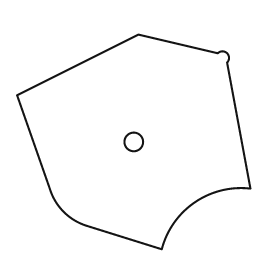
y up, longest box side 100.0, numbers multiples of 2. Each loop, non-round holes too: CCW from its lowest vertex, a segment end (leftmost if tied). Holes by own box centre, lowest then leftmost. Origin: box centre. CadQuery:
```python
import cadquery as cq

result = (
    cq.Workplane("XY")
    .moveTo(12.0, -46.0)
    .threePointArc((26.0, -26.0), (50.0, -20.0))
    .lineTo(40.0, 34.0)
    .threePointArc((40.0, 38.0), (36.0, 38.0))
    .lineTo(2.0, 46.0)
    .lineTo(-50.0, 20.0)
    .lineTo(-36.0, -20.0)
    .threePointArc((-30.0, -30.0), (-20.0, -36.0))
    .close()
    .moveTo(0.0, 0.0)
    .circle(4.0)
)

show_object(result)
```